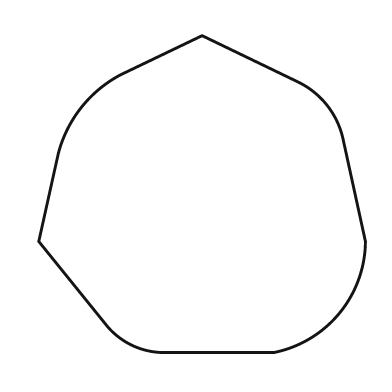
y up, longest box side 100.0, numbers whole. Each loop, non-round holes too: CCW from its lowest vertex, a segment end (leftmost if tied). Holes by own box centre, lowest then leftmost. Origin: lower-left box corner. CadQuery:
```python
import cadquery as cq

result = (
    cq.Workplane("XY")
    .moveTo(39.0, 0.0)
    .lineTo(72.0, 0.0)
    .threePointArc((92.0, 12.0), (100.0, 34.0))
    .lineTo(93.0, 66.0)
    .threePointArc((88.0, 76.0), (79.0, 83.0))
    .lineTo(50.0, 97.0)
    .lineTo(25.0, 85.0)
    .threePointArc((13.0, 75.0), (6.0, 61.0))
    .lineTo(0.0, 34.0)
    .lineTo(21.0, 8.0)
    .threePointArc((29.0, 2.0), (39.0, 0.0))
    .close()
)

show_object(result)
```